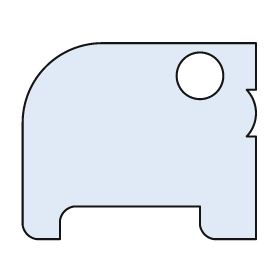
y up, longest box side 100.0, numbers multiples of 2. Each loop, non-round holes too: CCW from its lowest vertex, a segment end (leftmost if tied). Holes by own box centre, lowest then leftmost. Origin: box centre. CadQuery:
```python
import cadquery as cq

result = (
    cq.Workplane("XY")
    .moveTo(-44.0, -42.0)
    .lineTo(-34.0, -42.0)
    .lineTo(-34.0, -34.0)
    .threePointArc((-32.0, -30.0), (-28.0, -28.0))
    .lineTo(26.0, -28.0)
    .lineTo(26.0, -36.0)
    .threePointArc((28.0, -40.0), (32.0, -42.0))
    .lineTo(50.0, -42.0)
    .lineTo(50.0, 2.0)
    .lineTo(46.0, 2.0)
    .threePointArc((50.0, 12.0), (46.0, 22.0))
    .lineTo(50.0, 22.0)
    .lineTo(50.0, 42.0)
    .lineTo(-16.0, 42.0)
    .threePointArc((-40.0, 32.0), (-50.0, 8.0))
    .lineTo(-50.0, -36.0)
    .threePointArc((-48.0, -40.0), (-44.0, -42.0))
    .close()
    .moveTo(26.0, 28.0)
    .circle(10.0)
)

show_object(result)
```